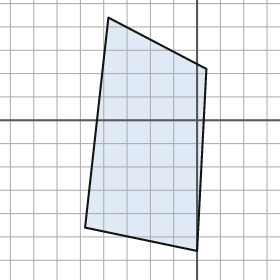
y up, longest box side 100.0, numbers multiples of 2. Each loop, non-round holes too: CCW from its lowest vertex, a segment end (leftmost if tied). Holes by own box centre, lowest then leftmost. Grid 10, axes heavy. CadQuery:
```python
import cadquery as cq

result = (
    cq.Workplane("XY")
    .moveTo(0.0, -56.0)
    .lineTo(4.0, 22.0)
    .lineTo(-38.0, 44.0)
    .lineTo(-48.0, -46.0)
    .close()
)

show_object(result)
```